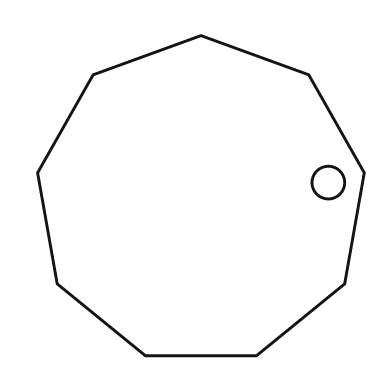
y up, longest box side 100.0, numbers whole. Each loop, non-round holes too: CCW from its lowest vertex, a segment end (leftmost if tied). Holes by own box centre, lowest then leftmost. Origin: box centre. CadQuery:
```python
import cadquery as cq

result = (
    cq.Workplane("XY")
    .moveTo(-17.0, -49.0)
    .lineTo(17.0, -49.0)
    .lineTo(44.0, -27.0)
    .lineTo(50.0, 7.0)
    .lineTo(33.0, 37.0)
    .lineTo(0.0, 49.0)
    .lineTo(-33.0, 37.0)
    .lineTo(-50.0, 7.0)
    .lineTo(-44.0, -27.0)
    .close()
    .moveTo(39.0, 4.0)
    .circle(5.0)
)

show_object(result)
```